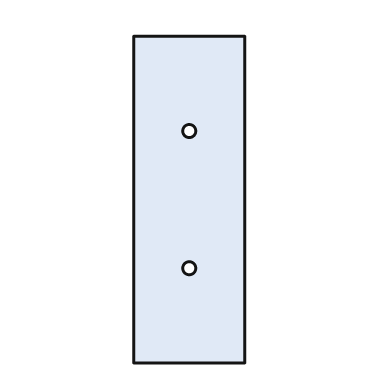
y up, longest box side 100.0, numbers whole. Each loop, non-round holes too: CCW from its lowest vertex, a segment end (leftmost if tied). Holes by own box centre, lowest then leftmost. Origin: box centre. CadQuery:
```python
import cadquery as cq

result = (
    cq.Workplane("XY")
    .moveTo(-17.0, -50.0)
    .lineTo(17.0, -50.0)
    .lineTo(17.0, 50.0)
    .lineTo(-17.0, 50.0)
    .close()
    .moveTo(0.0, -21.0)
    .circle(2.0)
    .moveTo(0.0, 21.0)
    .circle(2.0)
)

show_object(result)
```